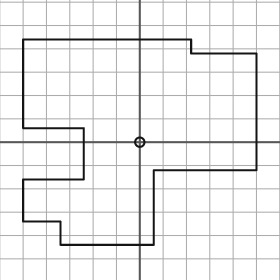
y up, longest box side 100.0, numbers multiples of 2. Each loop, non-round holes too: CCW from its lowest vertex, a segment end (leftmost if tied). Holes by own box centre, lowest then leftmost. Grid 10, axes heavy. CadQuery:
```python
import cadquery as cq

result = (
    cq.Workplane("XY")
    .moveTo(-34.0, -44.0)
    .lineTo(6.0, -44.0)
    .lineTo(6.0, -12.0)
    .lineTo(50.0, -12.0)
    .lineTo(50.0, 38.0)
    .lineTo(22.0, 38.0)
    .lineTo(22.0, 44.0)
    .lineTo(-50.0, 44.0)
    .lineTo(-50.0, 6.0)
    .lineTo(-24.0, 6.0)
    .lineTo(-24.0, -16.0)
    .lineTo(-50.0, -16.0)
    .lineTo(-50.0, -34.0)
    .lineTo(-34.0, -34.0)
    .close()
    .moveTo(0.0, 0.0)
    .circle(2.0)
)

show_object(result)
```